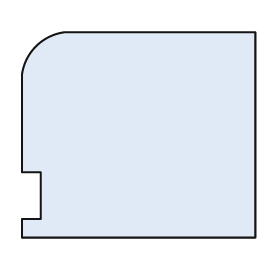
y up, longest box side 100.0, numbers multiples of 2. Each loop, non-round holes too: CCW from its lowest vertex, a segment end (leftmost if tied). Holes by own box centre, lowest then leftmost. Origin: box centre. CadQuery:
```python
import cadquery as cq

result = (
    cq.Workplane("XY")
    .moveTo(-50.0, -44.0)
    .lineTo(50.0, -44.0)
    .lineTo(50.0, 44.0)
    .lineTo(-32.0, 44.0)
    .threePointArc((-44.0, 38.0), (-50.0, 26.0))
    .lineTo(-50.0, -16.0)
    .lineTo(-42.0, -16.0)
    .lineTo(-42.0, -36.0)
    .lineTo(-50.0, -36.0)
    .close()
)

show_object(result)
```